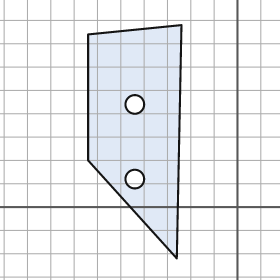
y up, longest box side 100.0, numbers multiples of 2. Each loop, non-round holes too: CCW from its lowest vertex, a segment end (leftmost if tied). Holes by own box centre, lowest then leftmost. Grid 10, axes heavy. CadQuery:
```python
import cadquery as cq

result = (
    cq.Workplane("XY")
    .moveTo(-26.0, -22.0)
    .lineTo(-24.0, 78.0)
    .lineTo(-64.0, 74.0)
    .lineTo(-64.0, 20.0)
    .close()
    .moveTo(-44.0, 12.0)
    .circle(4.0)
    .moveTo(-44.0, 44.0)
    .circle(4.0)
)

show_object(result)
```